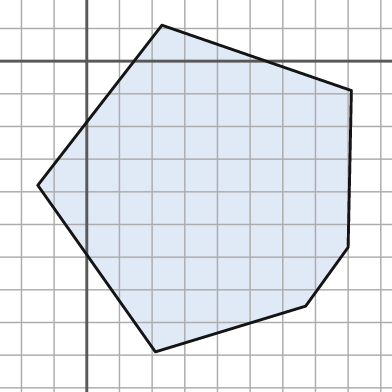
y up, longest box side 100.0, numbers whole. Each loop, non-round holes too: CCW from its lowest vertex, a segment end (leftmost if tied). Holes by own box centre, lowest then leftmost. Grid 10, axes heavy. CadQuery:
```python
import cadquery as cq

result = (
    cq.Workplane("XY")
    .moveTo(21.0, -89.0)
    .lineTo(67.0, -75.0)
    .lineTo(80.0, -57.0)
    .lineTo(81.0, -9.0)
    .lineTo(23.0, 11.0)
    .lineTo(-15.0, -38.0)
    .close()
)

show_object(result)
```